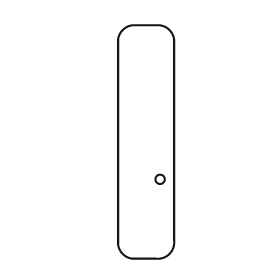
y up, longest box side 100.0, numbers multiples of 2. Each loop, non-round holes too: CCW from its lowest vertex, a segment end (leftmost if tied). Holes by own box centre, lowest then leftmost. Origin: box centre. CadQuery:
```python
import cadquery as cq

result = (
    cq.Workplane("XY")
    .moveTo(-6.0, -50.0)
    .lineTo(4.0, -50.0)
    .threePointArc((10.0, -48.0), (12.0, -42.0))
    .lineTo(12.0, 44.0)
    .threePointArc((10.0, 48.0), (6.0, 50.0))
    .lineTo(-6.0, 50.0)
    .threePointArc((-10.0, 48.0), (-12.0, 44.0))
    .lineTo(-12.0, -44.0)
    .threePointArc((-10.0, -48.0), (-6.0, -50.0))
    .close()
    .moveTo(6.0, -16.0)
    .circle(2.0)
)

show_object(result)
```